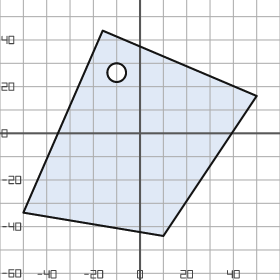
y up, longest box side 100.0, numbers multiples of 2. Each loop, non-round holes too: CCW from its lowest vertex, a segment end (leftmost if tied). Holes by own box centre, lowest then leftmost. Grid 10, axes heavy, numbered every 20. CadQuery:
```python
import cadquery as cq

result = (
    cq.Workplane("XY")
    .moveTo(10.0, -44.0)
    .lineTo(50.0, 16.0)
    .lineTo(-16.0, 44.0)
    .lineTo(-50.0, -34.0)
    .close()
    .moveTo(-10.0, 26.0)
    .circle(4.0)
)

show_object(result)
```